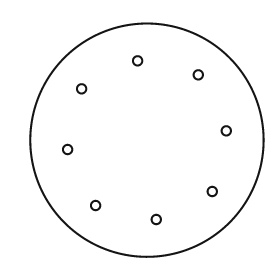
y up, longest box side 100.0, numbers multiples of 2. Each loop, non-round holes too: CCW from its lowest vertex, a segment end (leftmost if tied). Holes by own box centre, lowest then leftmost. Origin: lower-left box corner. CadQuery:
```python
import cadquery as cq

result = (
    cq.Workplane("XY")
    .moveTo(50.0, 50.0)
    .circle(50.0)
    .moveTo(54.0, 16.0)
    .circle(2.0)
    .moveTo(28.0, 22.0)
    .circle(2.0)
    .moveTo(78.0, 28.0)
    .circle(2.0)
    .moveTo(16.0, 46.0)
    .circle(2.0)
    .moveTo(84.0, 54.0)
    .circle(2.0)
    .moveTo(22.0, 72.0)
    .circle(2.0)
    .moveTo(72.0, 78.0)
    .circle(2.0)
    .moveTo(46.0, 84.0)
    .circle(2.0)
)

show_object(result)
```